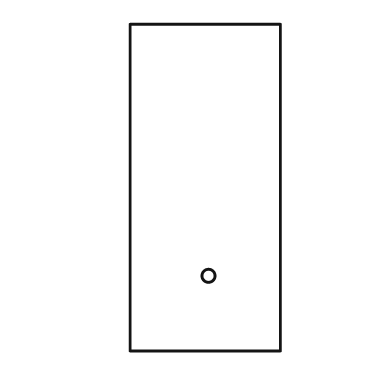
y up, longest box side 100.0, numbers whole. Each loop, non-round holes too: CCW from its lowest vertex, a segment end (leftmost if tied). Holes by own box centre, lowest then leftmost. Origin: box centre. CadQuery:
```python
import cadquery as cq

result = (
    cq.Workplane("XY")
    .moveTo(-23.0, -50.0)
    .lineTo(23.0, -50.0)
    .lineTo(23.0, 50.0)
    .lineTo(-23.0, 50.0)
    .close()
    .moveTo(1.0, -27.0)
    .circle(2.0)
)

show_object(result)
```